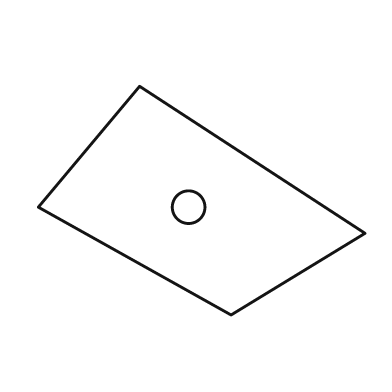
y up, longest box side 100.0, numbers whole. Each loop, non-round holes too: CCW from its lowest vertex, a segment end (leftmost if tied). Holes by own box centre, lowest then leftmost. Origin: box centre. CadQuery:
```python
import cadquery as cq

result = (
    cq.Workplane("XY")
    .moveTo(9.0, -35.0)
    .lineTo(50.0, -10.0)
    .lineTo(-19.0, 35.0)
    .lineTo(-50.0, -2.0)
    .close()
    .moveTo(-4.0, -2.0)
    .circle(5.0)
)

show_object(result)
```